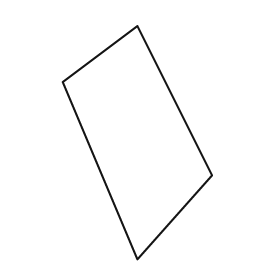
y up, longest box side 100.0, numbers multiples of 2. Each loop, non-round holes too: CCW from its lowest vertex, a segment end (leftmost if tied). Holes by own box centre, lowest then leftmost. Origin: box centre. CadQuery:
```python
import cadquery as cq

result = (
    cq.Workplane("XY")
    .moveTo(0.0, -50.0)
    .lineTo(32.0, -14.0)
    .lineTo(0.0, 50.0)
    .lineTo(-32.0, 26.0)
    .close()
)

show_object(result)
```